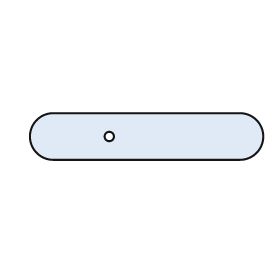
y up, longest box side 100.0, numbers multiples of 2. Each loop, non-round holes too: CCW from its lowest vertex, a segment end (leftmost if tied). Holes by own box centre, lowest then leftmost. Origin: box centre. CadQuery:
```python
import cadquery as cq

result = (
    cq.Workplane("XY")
    .moveTo(-40.0, -10.0)
    .lineTo(40.0, -10.0)
    .threePointArc((50.0, 0.0), (40.0, 10.0))
    .lineTo(-40.0, 10.0)
    .threePointArc((-50.0, 0.0), (-40.0, -10.0))
    .close()
    .moveTo(-16.0, 0.0)
    .circle(2.0)
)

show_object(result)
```